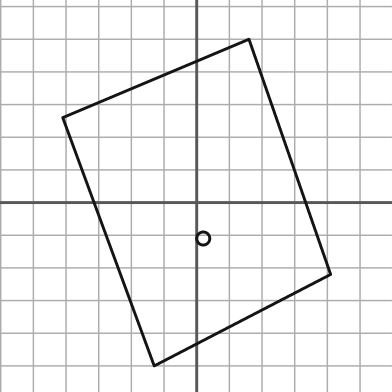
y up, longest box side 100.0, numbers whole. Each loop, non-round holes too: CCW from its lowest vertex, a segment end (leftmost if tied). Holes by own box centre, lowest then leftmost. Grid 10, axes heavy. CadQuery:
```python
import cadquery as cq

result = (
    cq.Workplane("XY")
    .moveTo(-13.0, -50.0)
    .lineTo(41.0, -22.0)
    .lineTo(16.0, 50.0)
    .lineTo(-41.0, 26.0)
    .close()
    .moveTo(2.0, -11.0)
    .circle(2.0)
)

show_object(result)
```